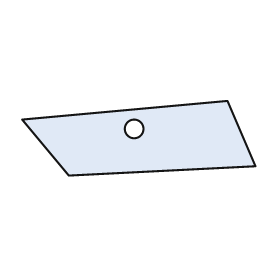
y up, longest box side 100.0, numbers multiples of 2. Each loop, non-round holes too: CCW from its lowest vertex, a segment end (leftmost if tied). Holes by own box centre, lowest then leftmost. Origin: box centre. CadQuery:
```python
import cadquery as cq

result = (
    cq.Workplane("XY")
    .moveTo(-30.0, -16.0)
    .lineTo(50.0, -12.0)
    .lineTo(38.0, 16.0)
    .lineTo(-50.0, 8.0)
    .close()
    .moveTo(-2.0, 4.0)
    .circle(4.0)
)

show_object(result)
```